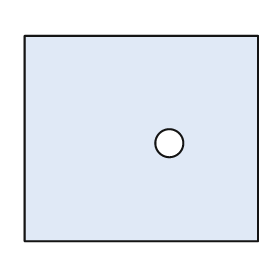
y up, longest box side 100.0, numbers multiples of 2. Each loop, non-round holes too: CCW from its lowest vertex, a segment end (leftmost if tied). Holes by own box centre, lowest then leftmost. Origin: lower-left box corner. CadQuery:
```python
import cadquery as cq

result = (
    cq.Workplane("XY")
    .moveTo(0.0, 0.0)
    .lineTo(100.0, 0.0)
    .lineTo(100.0, 88.0)
    .lineTo(0.0, 88.0)
    .close()
    .moveTo(62.0, 42.0)
    .circle(6.0)
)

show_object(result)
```